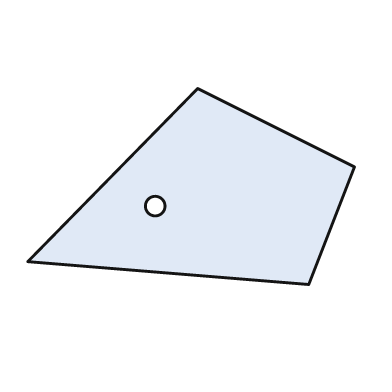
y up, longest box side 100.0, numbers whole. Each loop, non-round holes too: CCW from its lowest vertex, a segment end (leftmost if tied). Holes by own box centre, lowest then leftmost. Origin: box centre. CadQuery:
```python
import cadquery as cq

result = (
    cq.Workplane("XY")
    .moveTo(36.0, -30.0)
    .lineTo(50.0, 6.0)
    .lineTo(2.0, 30.0)
    .lineTo(-50.0, -23.0)
    .close()
    .moveTo(-11.0, -6.0)
    .circle(3.0)
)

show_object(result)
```